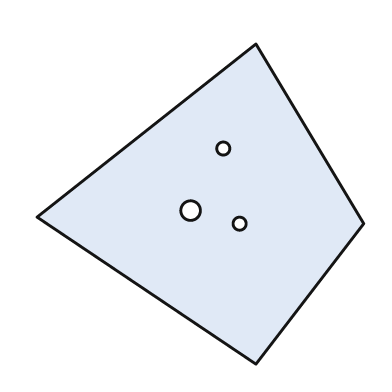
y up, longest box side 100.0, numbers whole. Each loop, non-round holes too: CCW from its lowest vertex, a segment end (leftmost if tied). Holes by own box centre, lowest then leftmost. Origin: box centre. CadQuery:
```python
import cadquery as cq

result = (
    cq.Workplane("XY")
    .moveTo(17.0, -49.0)
    .lineTo(50.0, -6.0)
    .lineTo(17.0, 49.0)
    .lineTo(-50.0, -4.0)
    .close()
    .moveTo(12.0, -6.0)
    .circle(2.0)
    .moveTo(-3.0, -2.0)
    .circle(3.0)
    .moveTo(7.0, 17.0)
    .circle(2.0)
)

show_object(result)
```